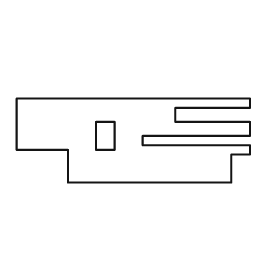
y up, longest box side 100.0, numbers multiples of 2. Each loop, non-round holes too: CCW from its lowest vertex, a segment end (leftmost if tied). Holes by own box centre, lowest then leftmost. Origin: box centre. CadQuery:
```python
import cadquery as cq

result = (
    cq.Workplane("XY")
    .moveTo(-28.0, -18.0)
    .lineTo(42.0, -18.0)
    .lineTo(42.0, -6.0)
    .lineTo(50.0, -6.0)
    .lineTo(50.0, -2.0)
    .lineTo(4.0, -2.0)
    .lineTo(4.0, 2.0)
    .lineTo(50.0, 2.0)
    .lineTo(50.0, 8.0)
    .lineTo(18.0, 8.0)
    .lineTo(18.0, 14.0)
    .lineTo(50.0, 14.0)
    .lineTo(50.0, 18.0)
    .lineTo(-50.0, 18.0)
    .lineTo(-50.0, -4.0)
    .lineTo(-28.0, -4.0)
    .close()
    .moveTo(-16.0, -4.0)
    .lineTo(-8.0, -4.0)
    .lineTo(-8.0, 8.0)
    .lineTo(-16.0, 8.0)
    .close()
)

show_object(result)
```